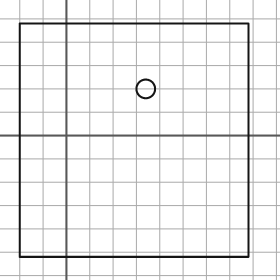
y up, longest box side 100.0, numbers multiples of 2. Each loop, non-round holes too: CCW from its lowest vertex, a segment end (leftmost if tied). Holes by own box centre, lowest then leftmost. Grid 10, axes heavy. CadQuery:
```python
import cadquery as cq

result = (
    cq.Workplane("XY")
    .moveTo(-20.0, -52.0)
    .lineTo(78.0, -52.0)
    .lineTo(78.0, 48.0)
    .lineTo(-20.0, 48.0)
    .close()
    .moveTo(34.0, 20.0)
    .circle(4.0)
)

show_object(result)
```